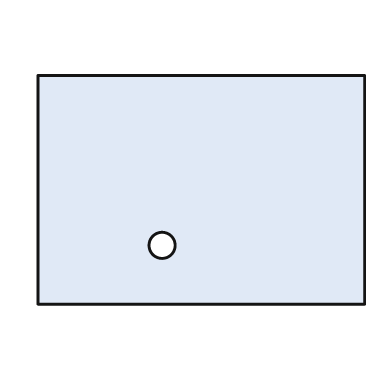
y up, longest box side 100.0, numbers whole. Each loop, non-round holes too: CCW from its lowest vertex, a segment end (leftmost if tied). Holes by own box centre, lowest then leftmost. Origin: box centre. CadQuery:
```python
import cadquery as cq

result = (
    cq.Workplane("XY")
    .moveTo(-50.0, -35.0)
    .lineTo(50.0, -35.0)
    .lineTo(50.0, 35.0)
    .lineTo(-50.0, 35.0)
    .close()
    .moveTo(-12.0, -17.0)
    .circle(4.0)
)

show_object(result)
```